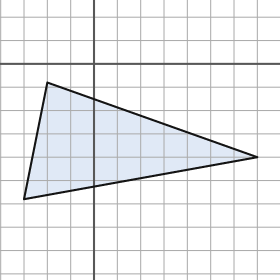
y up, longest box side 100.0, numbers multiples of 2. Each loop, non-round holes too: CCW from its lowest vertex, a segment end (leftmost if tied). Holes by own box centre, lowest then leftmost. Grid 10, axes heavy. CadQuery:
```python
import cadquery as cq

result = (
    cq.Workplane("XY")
    .moveTo(-30.0, -58.0)
    .lineTo(70.0, -40.0)
    .lineTo(-20.0, -8.0)
    .close()
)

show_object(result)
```